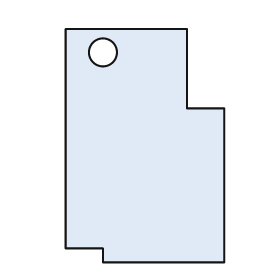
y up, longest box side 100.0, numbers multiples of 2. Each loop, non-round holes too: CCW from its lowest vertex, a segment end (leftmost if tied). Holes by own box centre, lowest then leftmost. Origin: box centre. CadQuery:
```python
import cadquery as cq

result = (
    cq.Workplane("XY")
    .moveTo(-18.0, -50.0)
    .lineTo(34.0, -50.0)
    .lineTo(34.0, 16.0)
    .lineTo(18.0, 16.0)
    .lineTo(18.0, 50.0)
    .lineTo(-34.0, 50.0)
    .lineTo(-34.0, -44.0)
    .lineTo(-18.0, -44.0)
    .close()
    .moveTo(-18.0, 40.0)
    .circle(6.0)
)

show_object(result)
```